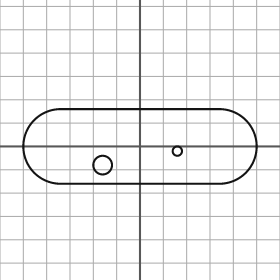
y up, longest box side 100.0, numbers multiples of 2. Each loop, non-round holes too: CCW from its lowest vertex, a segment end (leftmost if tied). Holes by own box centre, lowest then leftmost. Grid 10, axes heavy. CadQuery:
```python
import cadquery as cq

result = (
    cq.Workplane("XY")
    .moveTo(-34.0, -16.0)
    .lineTo(34.0, -16.0)
    .threePointArc((50.0, 0.0), (34.0, 16.0))
    .lineTo(-34.0, 16.0)
    .threePointArc((-50.0, 0.0), (-34.0, -16.0))
    .close()
    .moveTo(-16.0, -8.0)
    .circle(4.0)
    .moveTo(16.0, -2.0)
    .circle(2.0)
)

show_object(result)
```